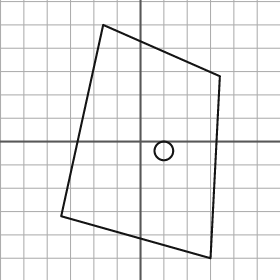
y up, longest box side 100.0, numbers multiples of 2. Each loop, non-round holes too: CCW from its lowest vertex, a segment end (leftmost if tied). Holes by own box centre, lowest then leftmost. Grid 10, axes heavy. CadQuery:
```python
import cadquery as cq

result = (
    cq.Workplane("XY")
    .moveTo(30.0, -50.0)
    .lineTo(34.0, 28.0)
    .lineTo(-16.0, 50.0)
    .lineTo(-34.0, -32.0)
    .close()
    .moveTo(10.0, -4.0)
    .circle(4.0)
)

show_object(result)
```